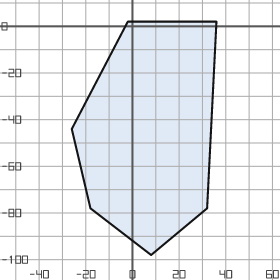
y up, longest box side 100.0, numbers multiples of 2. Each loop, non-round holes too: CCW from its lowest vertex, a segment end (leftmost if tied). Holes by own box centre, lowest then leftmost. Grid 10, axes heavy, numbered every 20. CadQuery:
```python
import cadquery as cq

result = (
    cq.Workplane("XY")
    .moveTo(8.0, -98.0)
    .lineTo(32.0, -78.0)
    .lineTo(36.0, 2.0)
    .lineTo(-2.0, 2.0)
    .lineTo(-26.0, -44.0)
    .lineTo(-18.0, -78.0)
    .close()
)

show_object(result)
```